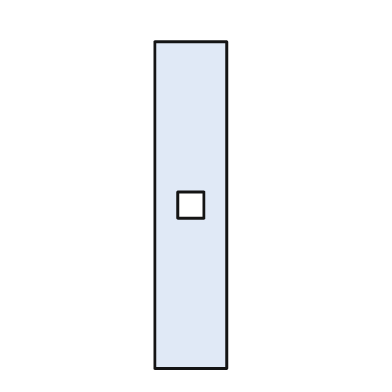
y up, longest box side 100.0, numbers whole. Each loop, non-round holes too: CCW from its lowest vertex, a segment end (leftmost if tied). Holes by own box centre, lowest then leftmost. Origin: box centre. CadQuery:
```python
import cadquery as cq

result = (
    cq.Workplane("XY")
    .moveTo(-11.0, -50.0)
    .lineTo(11.0, -50.0)
    .lineTo(11.0, 50.0)
    .lineTo(-11.0, 50.0)
    .close()
    .moveTo(-4.0, -4.0)
    .lineTo(4.0, -4.0)
    .lineTo(4.0, 4.0)
    .lineTo(-4.0, 4.0)
    .close()
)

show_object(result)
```